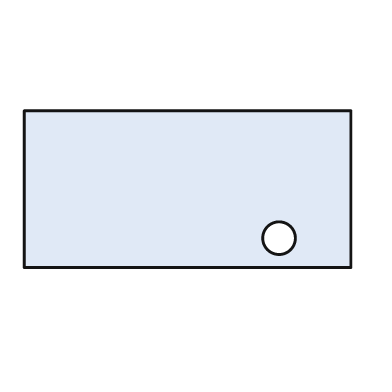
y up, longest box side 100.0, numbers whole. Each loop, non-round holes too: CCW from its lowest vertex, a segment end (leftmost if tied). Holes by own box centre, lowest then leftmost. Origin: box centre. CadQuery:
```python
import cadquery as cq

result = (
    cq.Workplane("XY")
    .moveTo(-50.0, -24.0)
    .lineTo(50.0, -24.0)
    .lineTo(50.0, 24.0)
    .lineTo(-50.0, 24.0)
    .close()
    .moveTo(28.0, -15.0)
    .circle(5.0)
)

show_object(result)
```